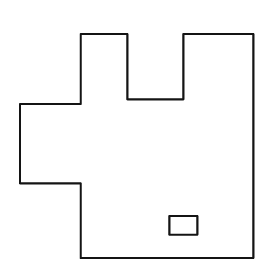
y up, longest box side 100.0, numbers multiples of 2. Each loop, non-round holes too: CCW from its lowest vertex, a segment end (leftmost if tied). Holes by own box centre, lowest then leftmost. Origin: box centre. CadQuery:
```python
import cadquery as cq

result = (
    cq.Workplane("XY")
    .moveTo(-24.0, -48.0)
    .lineTo(50.0, -48.0)
    .lineTo(50.0, 48.0)
    .lineTo(20.0, 48.0)
    .lineTo(20.0, 20.0)
    .lineTo(-4.0, 20.0)
    .lineTo(-4.0, 48.0)
    .lineTo(-24.0, 48.0)
    .lineTo(-24.0, 18.0)
    .lineTo(-50.0, 18.0)
    .lineTo(-50.0, -16.0)
    .lineTo(-24.0, -16.0)
    .close()
    .moveTo(14.0, -38.0)
    .lineTo(26.0, -38.0)
    .lineTo(26.0, -30.0)
    .lineTo(14.0, -30.0)
    .close()
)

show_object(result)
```